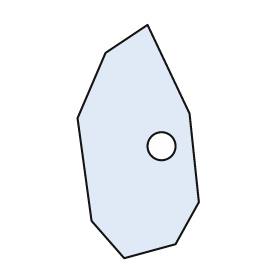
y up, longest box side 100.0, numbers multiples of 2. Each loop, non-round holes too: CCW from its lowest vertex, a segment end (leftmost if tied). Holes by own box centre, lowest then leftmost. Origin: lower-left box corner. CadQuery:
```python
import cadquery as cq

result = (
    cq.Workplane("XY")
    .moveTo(20.0, 0.0)
    .lineTo(42.0, 6.0)
    .lineTo(52.0, 24.0)
    .lineTo(48.0, 62.0)
    .lineTo(30.0, 100.0)
    .lineTo(12.0, 88.0)
    .lineTo(0.0, 60.0)
    .lineTo(6.0, 16.0)
    .close()
    .moveTo(36.0, 48.0)
    .circle(6.0)
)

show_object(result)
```